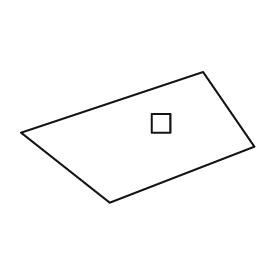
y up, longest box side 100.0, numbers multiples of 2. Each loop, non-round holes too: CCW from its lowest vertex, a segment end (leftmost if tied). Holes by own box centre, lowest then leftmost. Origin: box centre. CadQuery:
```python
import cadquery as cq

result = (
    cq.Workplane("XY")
    .moveTo(-12.0, -28.0)
    .lineTo(50.0, -4.0)
    .lineTo(28.0, 28.0)
    .lineTo(-50.0, 2.0)
    .close()
    .moveTo(6.0, 2.0)
    .lineTo(14.0, 2.0)
    .lineTo(14.0, 10.0)
    .lineTo(6.0, 10.0)
    .close()
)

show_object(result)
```